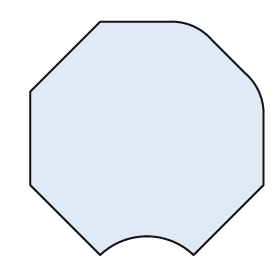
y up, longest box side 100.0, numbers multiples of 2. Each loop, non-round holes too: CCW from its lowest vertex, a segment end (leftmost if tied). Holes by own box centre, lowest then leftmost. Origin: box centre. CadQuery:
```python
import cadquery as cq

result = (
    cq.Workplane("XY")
    .moveTo(-20.0, -50.0)
    .threePointArc((0.0, -42.0), (20.0, -50.0))
    .lineTo(50.0, -20.0)
    .lineTo(50.0, 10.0)
    .threePointArc((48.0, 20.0), (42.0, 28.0))
    .lineTo(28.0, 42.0)
    .threePointArc((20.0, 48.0), (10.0, 50.0))
    .lineTo(-20.0, 50.0)
    .lineTo(-50.0, 20.0)
    .lineTo(-50.0, -20.0)
    .close()
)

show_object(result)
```